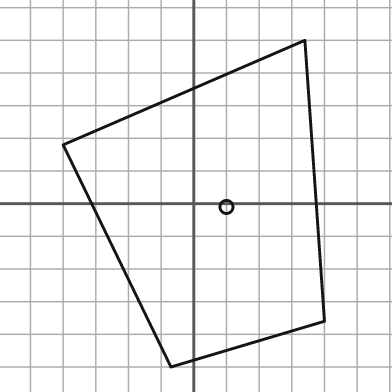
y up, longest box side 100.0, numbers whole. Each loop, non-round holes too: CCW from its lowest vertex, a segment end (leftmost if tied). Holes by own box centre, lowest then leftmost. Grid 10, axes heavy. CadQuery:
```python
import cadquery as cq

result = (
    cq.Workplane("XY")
    .moveTo(-7.0, -50.0)
    .lineTo(40.0, -36.0)
    .lineTo(34.0, 50.0)
    .lineTo(-40.0, 18.0)
    .close()
    .moveTo(10.0, -1.0)
    .circle(2.0)
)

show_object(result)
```